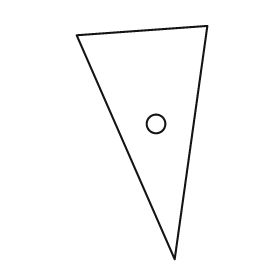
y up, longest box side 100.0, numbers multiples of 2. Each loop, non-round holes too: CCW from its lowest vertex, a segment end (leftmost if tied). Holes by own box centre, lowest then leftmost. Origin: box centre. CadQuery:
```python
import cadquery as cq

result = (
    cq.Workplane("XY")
    .moveTo(14.0, -50.0)
    .lineTo(28.0, 50.0)
    .lineTo(-28.0, 46.0)
    .close()
    .moveTo(6.0, 8.0)
    .circle(4.0)
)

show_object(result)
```